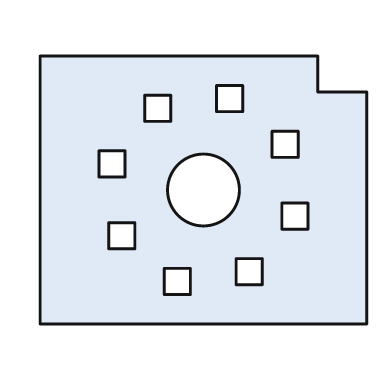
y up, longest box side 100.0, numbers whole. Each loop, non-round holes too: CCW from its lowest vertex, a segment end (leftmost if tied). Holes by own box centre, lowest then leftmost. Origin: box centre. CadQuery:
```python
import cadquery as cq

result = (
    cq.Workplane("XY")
    .moveTo(-50.0, -41.0)
    .lineTo(50.0, -41.0)
    .lineTo(50.0, 30.0)
    .lineTo(35.0, 30.0)
    .lineTo(35.0, 41.0)
    .lineTo(-50.0, 41.0)
    .close()
    .moveTo(-12.0, -32.0)
    .lineTo(-4.0, -32.0)
    .lineTo(-4.0, -24.0)
    .lineTo(-12.0, -24.0)
    .close()
    .moveTo(10.0, -29.0)
    .lineTo(18.0, -29.0)
    .lineTo(18.0, -21.0)
    .lineTo(10.0, -21.0)
    .close()
    .moveTo(-29.0, -18.0)
    .lineTo(-21.0, -18.0)
    .lineTo(-21.0, -10.0)
    .lineTo(-29.0, -10.0)
    .close()
    .moveTo(24.0, -12.0)
    .lineTo(32.0, -12.0)
    .lineTo(32.0, -4.0)
    .lineTo(24.0, -4.0)
    .close()
    .moveTo(0.0, 0.0)
    .circle(11.0)
    .moveTo(-32.0, 4.0)
    .lineTo(-24.0, 4.0)
    .lineTo(-24.0, 12.0)
    .lineTo(-32.0, 12.0)
    .close()
    .moveTo(21.0, 10.0)
    .lineTo(29.0, 10.0)
    .lineTo(29.0, 18.0)
    .lineTo(21.0, 18.0)
    .close()
    .moveTo(-18.0, 21.0)
    .lineTo(-10.0, 21.0)
    .lineTo(-10.0, 29.0)
    .lineTo(-18.0, 29.0)
    .close()
    .moveTo(4.0, 24.0)
    .lineTo(12.0, 24.0)
    .lineTo(12.0, 32.0)
    .lineTo(4.0, 32.0)
    .close()
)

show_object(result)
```